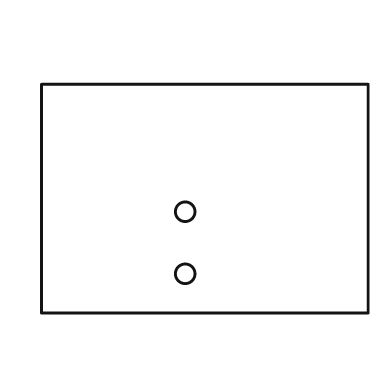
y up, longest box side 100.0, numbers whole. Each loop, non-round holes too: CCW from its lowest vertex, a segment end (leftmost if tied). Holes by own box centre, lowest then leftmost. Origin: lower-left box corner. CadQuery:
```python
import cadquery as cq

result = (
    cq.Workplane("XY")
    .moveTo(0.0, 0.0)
    .lineTo(100.0, 0.0)
    .lineTo(100.0, 70.0)
    .lineTo(0.0, 70.0)
    .close()
    .moveTo(44.0, 12.0)
    .circle(3.0)
    .moveTo(44.0, 31.0)
    .circle(3.0)
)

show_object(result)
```